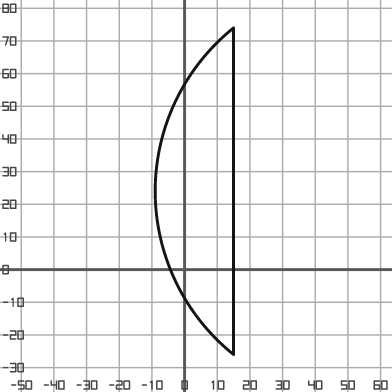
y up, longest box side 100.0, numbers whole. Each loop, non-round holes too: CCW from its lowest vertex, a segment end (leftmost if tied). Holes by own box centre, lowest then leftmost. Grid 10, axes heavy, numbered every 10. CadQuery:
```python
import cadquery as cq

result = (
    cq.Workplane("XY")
    .moveTo(15.0, -26.0)
    .lineTo(15.0, 74.0)
    .threePointArc((-9.0, 24.0), (15.0, -26.0))
    .close()
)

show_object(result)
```